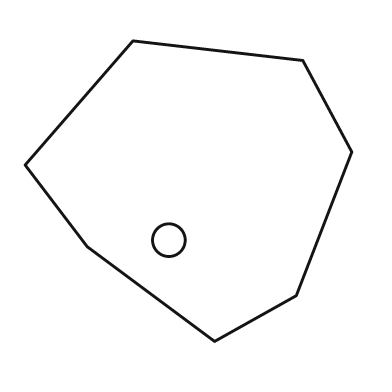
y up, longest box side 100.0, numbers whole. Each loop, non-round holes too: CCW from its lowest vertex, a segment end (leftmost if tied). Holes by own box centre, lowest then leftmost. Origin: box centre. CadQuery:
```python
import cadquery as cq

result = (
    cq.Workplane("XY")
    .moveTo(8.0, -46.0)
    .lineTo(33.0, -32.0)
    .lineTo(50.0, 12.0)
    .lineTo(35.0, 40.0)
    .lineTo(-17.0, 46.0)
    .lineTo(-50.0, 8.0)
    .lineTo(-31.0, -17.0)
    .close()
    .moveTo(-6.0, -15.0)
    .circle(5.0)
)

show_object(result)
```